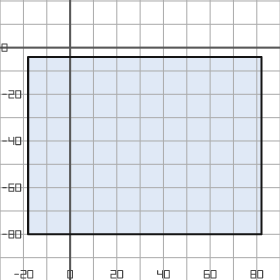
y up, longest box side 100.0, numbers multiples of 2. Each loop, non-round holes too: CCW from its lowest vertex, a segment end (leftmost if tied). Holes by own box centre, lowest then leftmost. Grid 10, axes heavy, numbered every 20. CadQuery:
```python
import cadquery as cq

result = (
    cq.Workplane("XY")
    .moveTo(-18.0, -80.0)
    .lineTo(82.0, -80.0)
    .lineTo(82.0, -4.0)
    .lineTo(-18.0, -4.0)
    .close()
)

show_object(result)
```